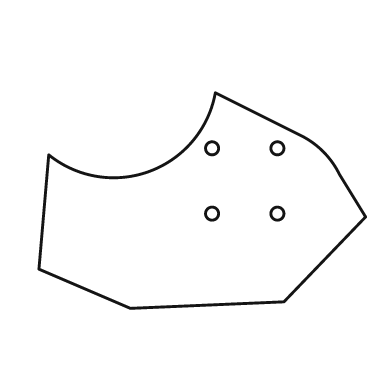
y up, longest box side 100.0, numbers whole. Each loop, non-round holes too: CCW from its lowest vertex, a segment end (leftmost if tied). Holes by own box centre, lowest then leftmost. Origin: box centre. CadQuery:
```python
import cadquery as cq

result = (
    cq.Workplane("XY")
    .moveTo(-22.0, -33.0)
    .lineTo(25.0, -31.0)
    .lineTo(50.0, -5.0)
    .lineTo(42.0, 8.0)
    .threePointArc((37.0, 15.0), (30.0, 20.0))
    .lineTo(4.0, 33.0)
    .threePointArc((-16.0, 9.0), (-47.0, 14.0))
    .lineTo(-50.0, -21.0)
    .close()
    .moveTo(3.0, -4.0)
    .circle(2.0)
    .moveTo(23.0, -4.0)
    .circle(2.0)
    .moveTo(3.0, 16.0)
    .circle(2.0)
    .moveTo(23.0, 16.0)
    .circle(2.0)
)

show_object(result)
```